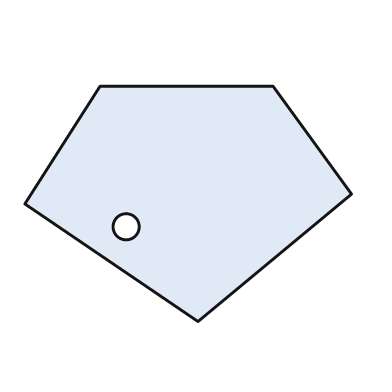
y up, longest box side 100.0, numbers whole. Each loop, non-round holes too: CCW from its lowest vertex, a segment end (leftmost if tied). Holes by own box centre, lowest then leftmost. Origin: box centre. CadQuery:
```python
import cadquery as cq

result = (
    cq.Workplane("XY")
    .moveTo(3.0, -36.0)
    .lineTo(50.0, 3.0)
    .lineTo(26.0, 36.0)
    .lineTo(-27.0, 36.0)
    .lineTo(-50.0, 0.0)
    .close()
    .moveTo(-19.0, -7.0)
    .circle(4.0)
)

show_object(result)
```